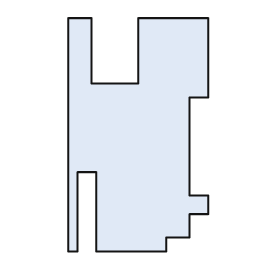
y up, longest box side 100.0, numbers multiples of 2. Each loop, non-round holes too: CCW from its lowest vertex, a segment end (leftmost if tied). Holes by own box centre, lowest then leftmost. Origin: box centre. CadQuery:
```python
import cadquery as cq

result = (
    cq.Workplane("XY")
    .moveTo(-30.0, -50.0)
    .lineTo(-26.0, -50.0)
    .lineTo(-26.0, -16.0)
    .lineTo(-18.0, -16.0)
    .lineTo(-18.0, -50.0)
    .lineTo(12.0, -50.0)
    .lineTo(12.0, -44.0)
    .lineTo(22.0, -44.0)
    .lineTo(22.0, -34.0)
    .lineTo(30.0, -34.0)
    .lineTo(30.0, -26.0)
    .lineTo(22.0, -26.0)
    .lineTo(22.0, 16.0)
    .lineTo(30.0, 16.0)
    .lineTo(30.0, 50.0)
    .lineTo(0.0, 50.0)
    .lineTo(0.0, 22.0)
    .lineTo(-20.0, 22.0)
    .lineTo(-20.0, 50.0)
    .lineTo(-30.0, 50.0)
    .close()
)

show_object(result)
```